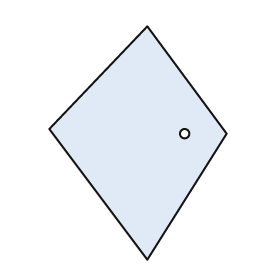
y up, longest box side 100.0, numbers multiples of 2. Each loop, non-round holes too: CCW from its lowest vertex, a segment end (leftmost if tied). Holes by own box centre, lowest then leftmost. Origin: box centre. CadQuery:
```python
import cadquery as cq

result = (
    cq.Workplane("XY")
    .moveTo(4.0, -50.0)
    .lineTo(38.0, 4.0)
    .lineTo(4.0, 50.0)
    .lineTo(-38.0, 6.0)
    .close()
    .moveTo(20.0, 4.0)
    .circle(2.0)
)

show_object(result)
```